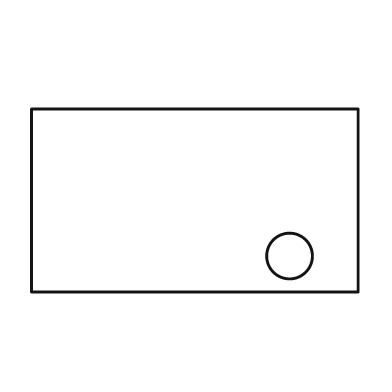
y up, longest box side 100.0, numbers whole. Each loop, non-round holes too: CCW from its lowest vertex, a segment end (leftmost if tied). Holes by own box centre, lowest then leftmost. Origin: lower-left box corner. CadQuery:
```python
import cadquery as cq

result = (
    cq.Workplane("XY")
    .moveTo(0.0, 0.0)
    .lineTo(100.0, 0.0)
    .lineTo(100.0, 56.0)
    .lineTo(0.0, 56.0)
    .close()
    .moveTo(79.0, 11.0)
    .circle(7.0)
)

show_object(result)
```